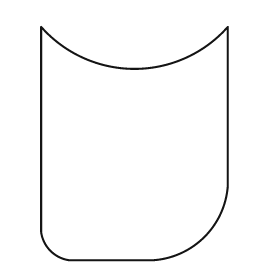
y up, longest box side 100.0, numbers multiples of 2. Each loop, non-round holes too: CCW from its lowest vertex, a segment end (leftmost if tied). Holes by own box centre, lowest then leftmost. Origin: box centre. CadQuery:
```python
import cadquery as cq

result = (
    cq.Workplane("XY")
    .moveTo(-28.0, -50.0)
    .lineTo(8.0, -50.0)
    .threePointArc((30.0, -40.0), (40.0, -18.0))
    .lineTo(40.0, 50.0)
    .threePointArc((0.0, 32.0), (-40.0, 50.0))
    .lineTo(-40.0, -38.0)
    .threePointArc((-36.0, -46.0), (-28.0, -50.0))
    .close()
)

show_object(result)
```